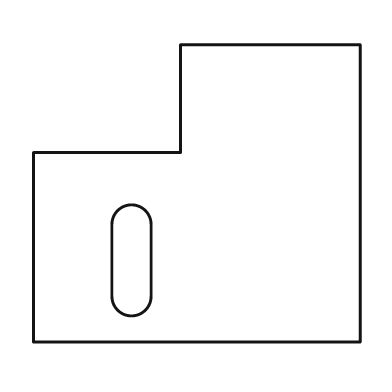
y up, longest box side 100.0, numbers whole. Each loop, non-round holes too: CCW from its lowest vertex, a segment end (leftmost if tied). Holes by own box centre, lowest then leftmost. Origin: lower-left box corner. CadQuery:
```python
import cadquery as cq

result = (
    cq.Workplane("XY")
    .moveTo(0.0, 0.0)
    .lineTo(100.0, 0.0)
    .lineTo(100.0, 91.0)
    .lineTo(45.0, 91.0)
    .lineTo(45.0, 58.0)
    .lineTo(0.0, 58.0)
    .close()
    .moveTo(24.0, 14.0)
    .threePointArc((30.0, 8.0), (36.0, 14.0))
    .lineTo(36.0, 36.0)
    .threePointArc((30.0, 42.0), (24.0, 36.0))
    .close()
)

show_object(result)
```